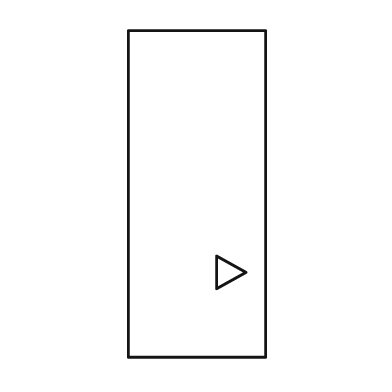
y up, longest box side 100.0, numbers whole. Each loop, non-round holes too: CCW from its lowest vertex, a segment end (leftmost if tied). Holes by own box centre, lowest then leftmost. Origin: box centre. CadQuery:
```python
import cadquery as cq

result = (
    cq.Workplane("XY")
    .moveTo(-21.0, -50.0)
    .lineTo(21.0, -50.0)
    .lineTo(21.0, 50.0)
    .lineTo(-21.0, 50.0)
    .close()
    .moveTo(6.0, -29.0)
    .lineTo(15.0, -24.0)
    .lineTo(6.0, -19.0)
    .close()
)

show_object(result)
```